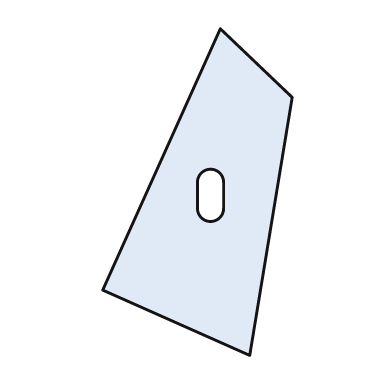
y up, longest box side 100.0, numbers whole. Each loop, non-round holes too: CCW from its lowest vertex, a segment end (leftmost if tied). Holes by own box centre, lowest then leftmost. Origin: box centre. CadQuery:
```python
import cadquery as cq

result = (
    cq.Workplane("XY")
    .moveTo(16.0, -50.0)
    .lineTo(29.0, 29.0)
    .lineTo(7.0, 50.0)
    .lineTo(-29.0, -30.0)
    .close()
    .moveTo(0.0, -5.0)
    .threePointArc((4.0, -9.0), (8.0, -5.0))
    .lineTo(8.0, 3.0)
    .threePointArc((4.0, 7.0), (0.0, 3.0))
    .close()
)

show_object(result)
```